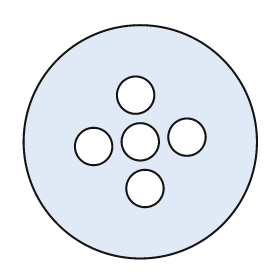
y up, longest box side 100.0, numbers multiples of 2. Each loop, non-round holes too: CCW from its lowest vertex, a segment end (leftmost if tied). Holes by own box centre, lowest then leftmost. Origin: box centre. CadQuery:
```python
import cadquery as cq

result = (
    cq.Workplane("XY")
    .moveTo(0.0, 0.0)
    .circle(50.0)
    .moveTo(2.0, -20.0)
    .circle(8.0)
    .moveTo(-20.0, -2.0)
    .circle(8.0)
    .moveTo(0.0, 0.0)
    .circle(8.0)
    .moveTo(20.0, 2.0)
    .circle(8.0)
    .moveTo(-2.0, 20.0)
    .circle(8.0)
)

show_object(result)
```